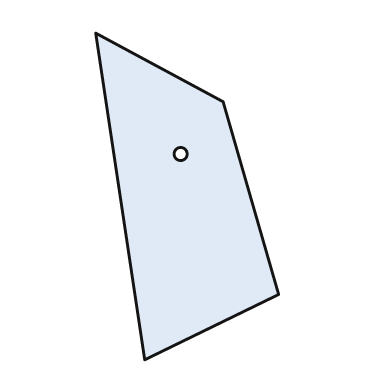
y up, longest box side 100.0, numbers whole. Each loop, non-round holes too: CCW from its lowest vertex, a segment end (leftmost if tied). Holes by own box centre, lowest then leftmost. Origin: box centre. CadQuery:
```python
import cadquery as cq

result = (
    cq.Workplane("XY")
    .moveTo(-13.0, -50.0)
    .lineTo(28.0, -30.0)
    .lineTo(11.0, 29.0)
    .lineTo(-28.0, 50.0)
    .close()
    .moveTo(-2.0, 13.0)
    .circle(2.0)
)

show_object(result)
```